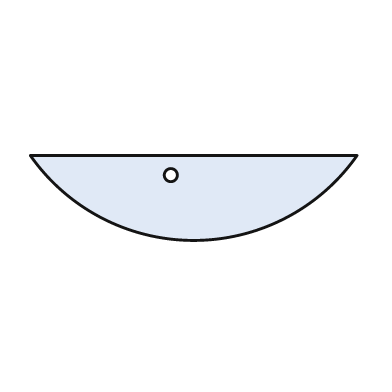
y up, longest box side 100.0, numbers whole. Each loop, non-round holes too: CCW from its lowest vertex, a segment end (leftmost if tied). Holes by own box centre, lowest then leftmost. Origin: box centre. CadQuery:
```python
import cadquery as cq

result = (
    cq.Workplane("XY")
    .moveTo(-50.0, 13.0)
    .threePointArc((0.0, -13.0), (50.0, 13.0))
    .close()
    .moveTo(-7.0, 7.0)
    .circle(2.0)
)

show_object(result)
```